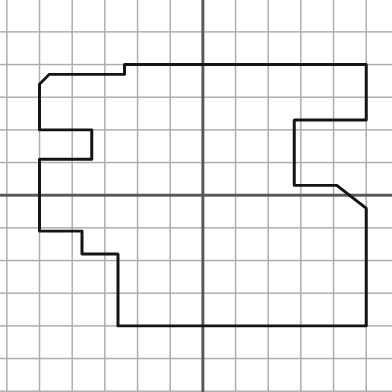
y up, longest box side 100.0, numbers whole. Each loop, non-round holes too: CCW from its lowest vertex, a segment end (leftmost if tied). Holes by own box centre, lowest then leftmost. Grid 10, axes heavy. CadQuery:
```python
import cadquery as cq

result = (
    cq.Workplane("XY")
    .moveTo(-26.0, -40.0)
    .lineTo(50.0, -40.0)
    .lineTo(50.0, -4.0)
    .lineTo(41.0, 3.0)
    .lineTo(28.0, 3.0)
    .lineTo(28.0, 23.0)
    .lineTo(50.0, 23.0)
    .lineTo(50.0, 40.0)
    .lineTo(-24.0, 40.0)
    .lineTo(-24.0, 37.0)
    .lineTo(-47.0, 37.0)
    .lineTo(-50.0, 34.0)
    .lineTo(-50.0, 20.0)
    .lineTo(-34.0, 20.0)
    .lineTo(-34.0, 11.0)
    .lineTo(-50.0, 11.0)
    .lineTo(-50.0, -11.0)
    .lineTo(-37.0, -11.0)
    .lineTo(-37.0, -18.0)
    .lineTo(-26.0, -18.0)
    .close()
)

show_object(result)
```